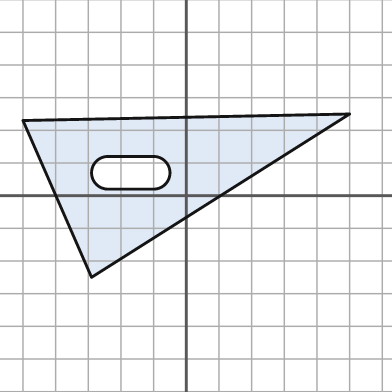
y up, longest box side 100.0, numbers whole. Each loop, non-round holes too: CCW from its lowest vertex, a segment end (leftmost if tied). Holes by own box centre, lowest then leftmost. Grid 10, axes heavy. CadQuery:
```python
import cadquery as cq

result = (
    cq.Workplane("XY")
    .moveTo(-29.0, -25.0)
    .lineTo(50.0, 25.0)
    .lineTo(-50.0, 23.0)
    .close()
    .moveTo(-24.0, 2.0)
    .lineTo(-10.0, 2.0)
    .threePointArc((-5.0, 7.0), (-10.0, 12.0))
    .lineTo(-24.0, 12.0)
    .threePointArc((-29.0, 7.0), (-24.0, 2.0))
    .close()
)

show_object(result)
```